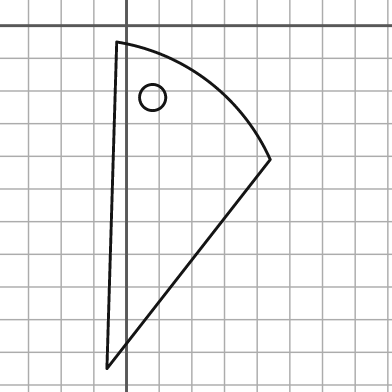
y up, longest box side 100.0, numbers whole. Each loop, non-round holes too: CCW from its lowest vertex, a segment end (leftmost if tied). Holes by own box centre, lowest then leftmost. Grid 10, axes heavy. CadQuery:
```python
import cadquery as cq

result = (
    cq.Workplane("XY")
    .moveTo(-6.0, -105.0)
    .lineTo(44.0, -41.0)
    .threePointArc((25.0, -17.0), (-3.0, -5.0))
    .close()
    .moveTo(8.0, -22.0)
    .circle(4.0)
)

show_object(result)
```